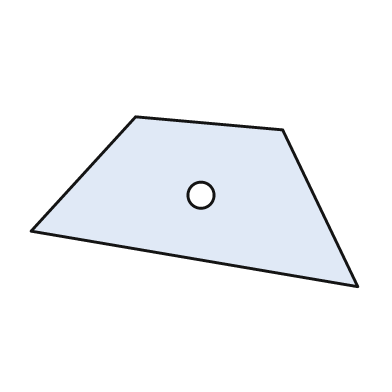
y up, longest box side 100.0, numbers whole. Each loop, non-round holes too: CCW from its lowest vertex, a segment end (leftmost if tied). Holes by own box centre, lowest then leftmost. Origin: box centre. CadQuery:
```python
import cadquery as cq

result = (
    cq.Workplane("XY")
    .moveTo(50.0, -26.0)
    .lineTo(27.0, 22.0)
    .lineTo(-18.0, 26.0)
    .lineTo(-50.0, -9.0)
    .close()
    .moveTo(2.0, 2.0)
    .circle(4.0)
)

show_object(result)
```